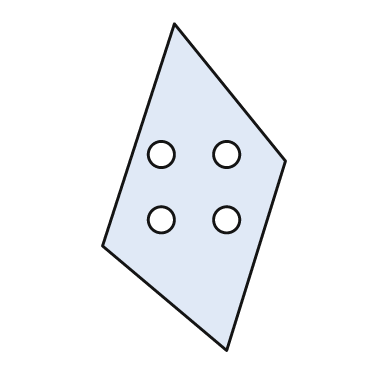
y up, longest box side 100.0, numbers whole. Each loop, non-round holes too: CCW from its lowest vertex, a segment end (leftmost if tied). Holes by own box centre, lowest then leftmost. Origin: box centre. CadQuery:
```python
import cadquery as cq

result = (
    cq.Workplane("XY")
    .moveTo(10.0, -50.0)
    .lineTo(28.0, 8.0)
    .lineTo(-6.0, 50.0)
    .lineTo(-28.0, -18.0)
    .close()
    .moveTo(-10.0, -10.0)
    .circle(4.0)
    .moveTo(10.0, -10.0)
    .circle(4.0)
    .moveTo(-10.0, 10.0)
    .circle(4.0)
    .moveTo(10.0, 10.0)
    .circle(4.0)
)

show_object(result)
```